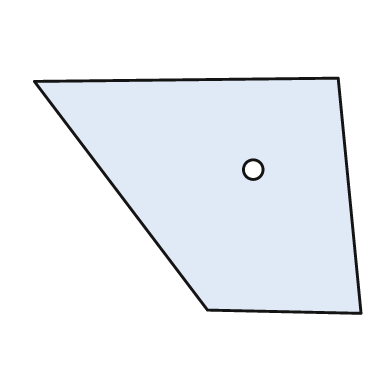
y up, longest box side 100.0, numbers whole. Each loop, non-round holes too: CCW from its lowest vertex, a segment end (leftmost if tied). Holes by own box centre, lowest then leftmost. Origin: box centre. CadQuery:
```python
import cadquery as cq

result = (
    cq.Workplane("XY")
    .moveTo(50.0, -36.0)
    .lineTo(43.0, 36.0)
    .lineTo(-50.0, 35.0)
    .lineTo(3.0, -35.0)
    .close()
    .moveTo(17.0, 8.0)
    .circle(3.0)
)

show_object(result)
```